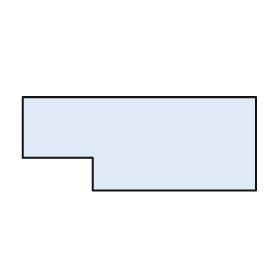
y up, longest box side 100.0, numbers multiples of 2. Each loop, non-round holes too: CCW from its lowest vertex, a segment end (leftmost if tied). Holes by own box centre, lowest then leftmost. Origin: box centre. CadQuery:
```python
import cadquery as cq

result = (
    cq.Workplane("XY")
    .moveTo(-20.0, -20.0)
    .lineTo(50.0, -20.0)
    .lineTo(50.0, 20.0)
    .lineTo(-50.0, 20.0)
    .lineTo(-50.0, -6.0)
    .lineTo(-20.0, -6.0)
    .close()
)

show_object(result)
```